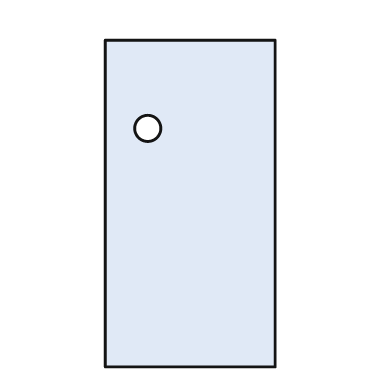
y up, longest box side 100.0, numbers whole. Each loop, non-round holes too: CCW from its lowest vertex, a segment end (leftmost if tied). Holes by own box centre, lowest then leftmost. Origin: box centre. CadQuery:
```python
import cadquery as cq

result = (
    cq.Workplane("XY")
    .moveTo(-26.0, -50.0)
    .lineTo(26.0, -50.0)
    .lineTo(26.0, 50.0)
    .lineTo(-26.0, 50.0)
    .close()
    .moveTo(-13.0, 23.0)
    .circle(4.0)
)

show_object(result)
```